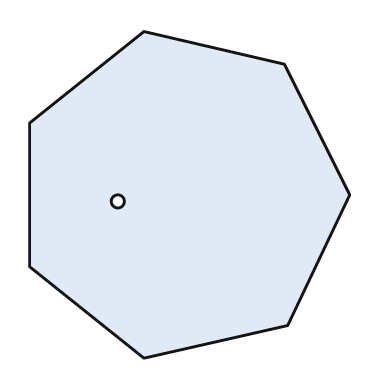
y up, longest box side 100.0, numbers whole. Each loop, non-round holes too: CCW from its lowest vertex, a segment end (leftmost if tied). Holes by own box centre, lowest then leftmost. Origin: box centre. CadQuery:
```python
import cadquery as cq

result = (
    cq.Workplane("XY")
    .moveTo(-14.0, -50.0)
    .lineTo(30.0, -40.0)
    .lineTo(49.0, 0.0)
    .lineTo(29.0, 40.0)
    .lineTo(-14.0, 50.0)
    .lineTo(-49.0, 22.0)
    .lineTo(-49.0, -22.0)
    .close()
    .moveTo(-22.0, -2.0)
    .circle(2.0)
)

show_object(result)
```